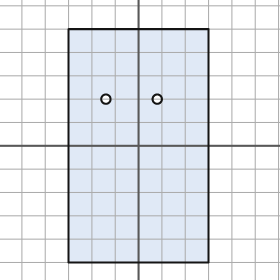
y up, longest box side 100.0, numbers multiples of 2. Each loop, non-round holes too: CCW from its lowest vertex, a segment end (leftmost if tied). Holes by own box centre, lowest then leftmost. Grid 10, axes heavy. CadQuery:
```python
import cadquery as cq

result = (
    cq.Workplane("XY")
    .moveTo(-30.0, -50.0)
    .lineTo(30.0, -50.0)
    .lineTo(30.0, 50.0)
    .lineTo(-30.0, 50.0)
    .close()
    .moveTo(-14.0, 20.0)
    .circle(2.0)
    .moveTo(8.0, 20.0)
    .circle(2.0)
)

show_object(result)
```